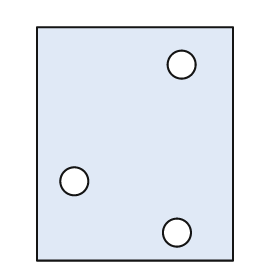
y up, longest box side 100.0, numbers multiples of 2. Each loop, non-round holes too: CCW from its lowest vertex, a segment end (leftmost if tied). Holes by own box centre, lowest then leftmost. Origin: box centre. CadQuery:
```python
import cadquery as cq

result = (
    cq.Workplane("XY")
    .moveTo(-42.0, -50.0)
    .lineTo(42.0, -50.0)
    .lineTo(42.0, 50.0)
    .lineTo(-42.0, 50.0)
    .close()
    .moveTo(18.0, -38.0)
    .circle(6.0)
    .moveTo(-26.0, -16.0)
    .circle(6.0)
    .moveTo(20.0, 34.0)
    .circle(6.0)
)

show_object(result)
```